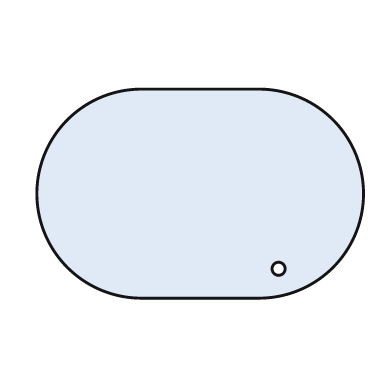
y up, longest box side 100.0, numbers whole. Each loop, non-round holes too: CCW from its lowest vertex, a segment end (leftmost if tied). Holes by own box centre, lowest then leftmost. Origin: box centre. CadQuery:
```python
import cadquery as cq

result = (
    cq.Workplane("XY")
    .moveTo(-18.0, -32.0)
    .lineTo(18.0, -32.0)
    .threePointArc((50.0, 0.0), (18.0, 32.0))
    .lineTo(-18.0, 32.0)
    .threePointArc((-50.0, 0.0), (-18.0, -32.0))
    .close()
    .moveTo(24.0, -23.0)
    .circle(2.0)
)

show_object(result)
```